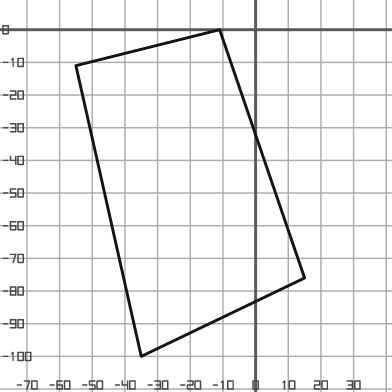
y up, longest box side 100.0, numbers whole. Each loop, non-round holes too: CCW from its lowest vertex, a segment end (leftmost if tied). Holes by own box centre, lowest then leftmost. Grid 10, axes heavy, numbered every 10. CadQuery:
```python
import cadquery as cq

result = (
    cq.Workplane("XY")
    .moveTo(-35.0, -100.0)
    .lineTo(15.0, -76.0)
    .lineTo(-11.0, 0.0)
    .lineTo(-55.0, -11.0)
    .close()
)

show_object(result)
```